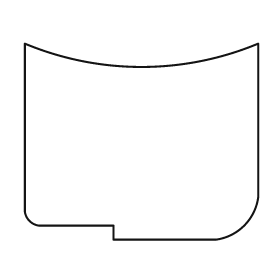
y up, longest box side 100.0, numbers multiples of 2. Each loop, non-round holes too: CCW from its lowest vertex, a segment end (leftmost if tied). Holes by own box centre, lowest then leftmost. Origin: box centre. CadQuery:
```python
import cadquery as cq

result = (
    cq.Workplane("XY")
    .moveTo(-12.0, -42.0)
    .lineTo(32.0, -42.0)
    .threePointArc((44.0, -36.0), (50.0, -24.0))
    .lineTo(50.0, 42.0)
    .threePointArc((0.0, 32.0), (-50.0, 42.0))
    .lineTo(-50.0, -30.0)
    .threePointArc((-48.0, -34.0), (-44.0, -36.0))
    .lineTo(-12.0, -36.0)
    .close()
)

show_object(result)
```